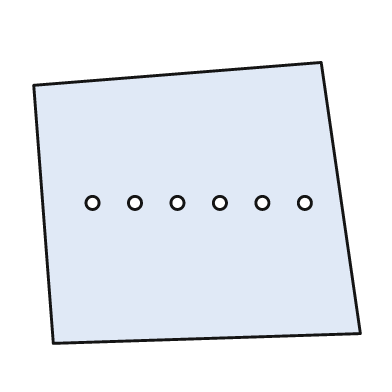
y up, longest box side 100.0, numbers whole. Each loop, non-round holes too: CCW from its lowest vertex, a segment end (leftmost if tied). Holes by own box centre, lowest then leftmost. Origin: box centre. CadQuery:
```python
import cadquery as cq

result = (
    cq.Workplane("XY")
    .moveTo(-44.0, -43.0)
    .lineTo(50.0, -40.0)
    .lineTo(38.0, 43.0)
    .lineTo(-50.0, 36.0)
    .close()
    .moveTo(-32.0, 0.0)
    .circle(2.0)
    .moveTo(-19.0, 0.0)
    .circle(2.0)
    .moveTo(-6.0, 0.0)
    .circle(2.0)
    .moveTo(7.0, 0.0)
    .circle(2.0)
    .moveTo(20.0, 0.0)
    .circle(2.0)
    .moveTo(33.0, 0.0)
    .circle(2.0)
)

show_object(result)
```